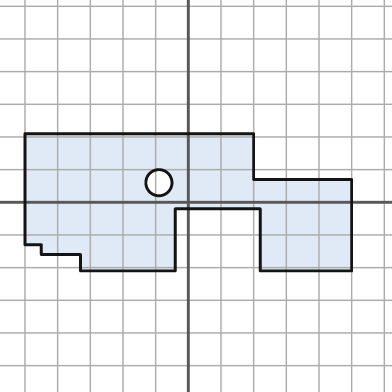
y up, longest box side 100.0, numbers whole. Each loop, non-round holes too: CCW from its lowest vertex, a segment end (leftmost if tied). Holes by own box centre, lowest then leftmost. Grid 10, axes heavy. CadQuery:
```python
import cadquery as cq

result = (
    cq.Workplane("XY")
    .moveTo(-33.0, -21.0)
    .lineTo(-4.0, -21.0)
    .lineTo(-4.0, -2.0)
    .lineTo(22.0, -2.0)
    .lineTo(22.0, -21.0)
    .lineTo(50.0, -21.0)
    .lineTo(50.0, 7.0)
    .lineTo(20.0, 7.0)
    .lineTo(20.0, 21.0)
    .lineTo(-50.0, 21.0)
    .lineTo(-50.0, -13.0)
    .lineTo(-45.0, -13.0)
    .lineTo(-45.0, -16.0)
    .lineTo(-33.0, -16.0)
    .close()
    .moveTo(-9.0, 6.0)
    .circle(4.0)
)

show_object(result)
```